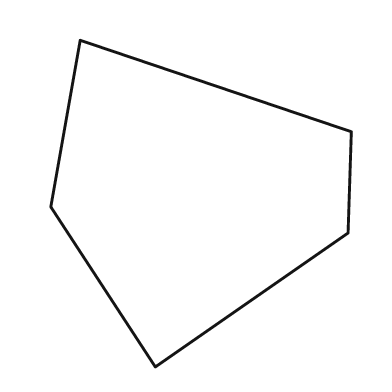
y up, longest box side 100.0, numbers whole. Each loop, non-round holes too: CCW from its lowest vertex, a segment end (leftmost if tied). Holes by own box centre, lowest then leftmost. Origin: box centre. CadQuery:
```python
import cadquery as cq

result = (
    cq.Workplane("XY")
    .moveTo(-14.0, -50.0)
    .lineTo(45.0, -9.0)
    .lineTo(46.0, 22.0)
    .lineTo(-37.0, 50.0)
    .lineTo(-46.0, -1.0)
    .close()
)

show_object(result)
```